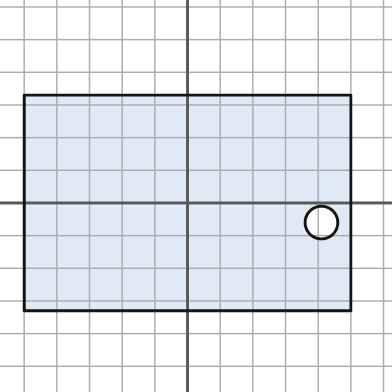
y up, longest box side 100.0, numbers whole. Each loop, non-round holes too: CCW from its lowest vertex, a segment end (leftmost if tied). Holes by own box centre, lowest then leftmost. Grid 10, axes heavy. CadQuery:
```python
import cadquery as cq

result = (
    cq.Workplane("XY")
    .moveTo(-50.0, -33.0)
    .lineTo(50.0, -33.0)
    .lineTo(50.0, 33.0)
    .lineTo(-50.0, 33.0)
    .close()
    .moveTo(41.0, -6.0)
    .circle(5.0)
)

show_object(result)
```